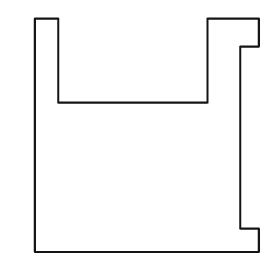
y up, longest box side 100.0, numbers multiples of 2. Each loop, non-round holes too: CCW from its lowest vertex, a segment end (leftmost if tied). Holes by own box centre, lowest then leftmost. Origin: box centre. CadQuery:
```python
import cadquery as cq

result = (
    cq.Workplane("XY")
    .moveTo(-48.0, -50.0)
    .lineTo(48.0, -50.0)
    .lineTo(48.0, -40.0)
    .lineTo(40.0, -40.0)
    .lineTo(40.0, 38.0)
    .lineTo(48.0, 38.0)
    .lineTo(48.0, 50.0)
    .lineTo(26.0, 50.0)
    .lineTo(26.0, 14.0)
    .lineTo(-38.0, 14.0)
    .lineTo(-38.0, 50.0)
    .lineTo(-48.0, 50.0)
    .close()
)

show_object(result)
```